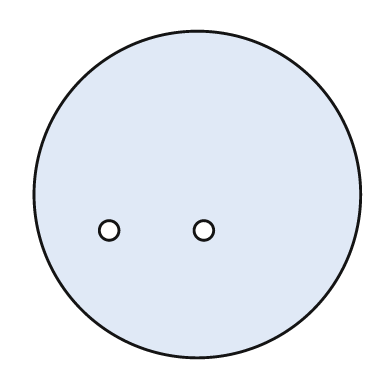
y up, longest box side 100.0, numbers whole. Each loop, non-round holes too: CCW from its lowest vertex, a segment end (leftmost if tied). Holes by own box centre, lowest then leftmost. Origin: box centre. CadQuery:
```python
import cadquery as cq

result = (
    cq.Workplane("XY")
    .moveTo(0.0, 0.0)
    .circle(50.0)
    .moveTo(-27.0, -11.0)
    .circle(3.0)
    .moveTo(2.0, -11.0)
    .circle(3.0)
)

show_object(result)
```